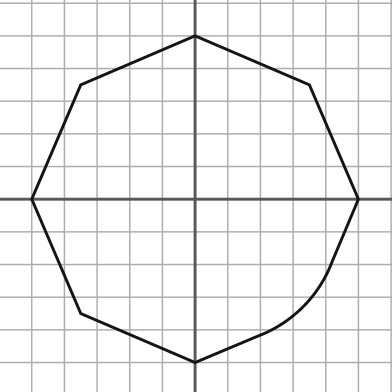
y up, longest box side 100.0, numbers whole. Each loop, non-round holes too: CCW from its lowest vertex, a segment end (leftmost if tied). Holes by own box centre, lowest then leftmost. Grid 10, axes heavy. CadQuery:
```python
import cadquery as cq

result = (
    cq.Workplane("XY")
    .moveTo(0.0, -50.0)
    .lineTo(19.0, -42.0)
    .threePointArc((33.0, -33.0), (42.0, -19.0))
    .lineTo(50.0, 0.0)
    .lineTo(35.0, 35.0)
    .lineTo(0.0, 50.0)
    .lineTo(-35.0, 35.0)
    .lineTo(-50.0, 0.0)
    .lineTo(-35.0, -35.0)
    .close()
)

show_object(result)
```